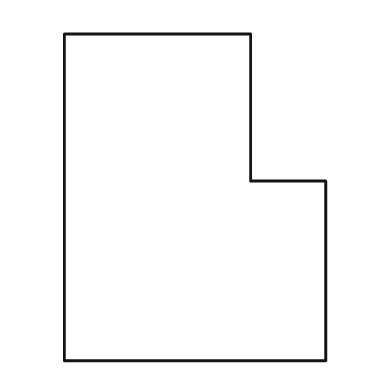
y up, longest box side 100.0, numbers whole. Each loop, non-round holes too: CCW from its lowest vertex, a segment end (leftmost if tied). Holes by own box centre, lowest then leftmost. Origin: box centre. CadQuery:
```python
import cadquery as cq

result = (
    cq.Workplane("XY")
    .moveTo(-40.0, -50.0)
    .lineTo(40.0, -50.0)
    .lineTo(40.0, 5.0)
    .lineTo(17.0, 5.0)
    .lineTo(17.0, 50.0)
    .lineTo(-40.0, 50.0)
    .close()
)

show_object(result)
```